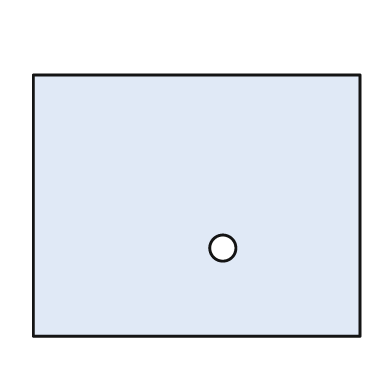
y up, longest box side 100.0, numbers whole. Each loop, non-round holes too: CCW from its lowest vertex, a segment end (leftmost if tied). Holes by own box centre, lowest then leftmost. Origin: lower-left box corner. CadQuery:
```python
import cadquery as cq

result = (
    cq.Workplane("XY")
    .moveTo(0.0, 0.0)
    .lineTo(100.0, 0.0)
    .lineTo(100.0, 80.0)
    .lineTo(0.0, 80.0)
    .close()
    .moveTo(58.0, 27.0)
    .circle(4.0)
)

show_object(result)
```